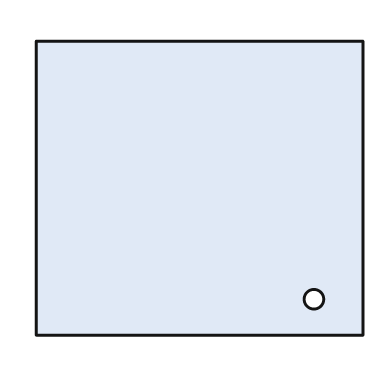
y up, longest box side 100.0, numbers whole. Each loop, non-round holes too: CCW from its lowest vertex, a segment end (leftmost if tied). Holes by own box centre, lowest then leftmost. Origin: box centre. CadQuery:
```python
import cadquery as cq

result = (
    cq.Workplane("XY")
    .moveTo(-50.0, -45.0)
    .lineTo(50.0, -45.0)
    .lineTo(50.0, 45.0)
    .lineTo(-50.0, 45.0)
    .close()
    .moveTo(35.0, -34.0)
    .circle(3.0)
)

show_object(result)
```